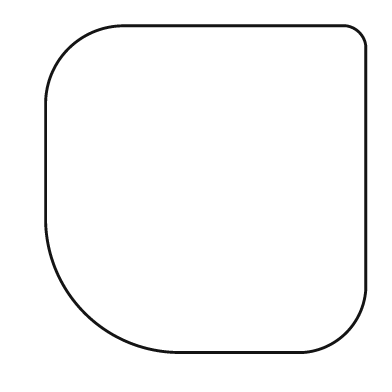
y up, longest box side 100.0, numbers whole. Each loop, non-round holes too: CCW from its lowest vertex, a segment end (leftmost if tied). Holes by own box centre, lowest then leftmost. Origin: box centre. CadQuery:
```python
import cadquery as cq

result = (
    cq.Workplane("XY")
    .moveTo(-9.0, -50.0)
    .lineTo(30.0, -50.0)
    .threePointArc((43.0, -44.0), (49.0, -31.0))
    .lineTo(49.0, 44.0)
    .threePointArc((47.0, 48.0), (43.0, 50.0))
    .lineTo(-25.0, 50.0)
    .threePointArc((-42.0, 43.0), (-49.0, 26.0))
    .lineTo(-49.0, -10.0)
    .threePointArc((-37.0, -38.0), (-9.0, -50.0))
    .close()
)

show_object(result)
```